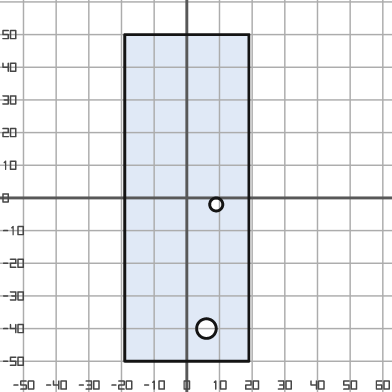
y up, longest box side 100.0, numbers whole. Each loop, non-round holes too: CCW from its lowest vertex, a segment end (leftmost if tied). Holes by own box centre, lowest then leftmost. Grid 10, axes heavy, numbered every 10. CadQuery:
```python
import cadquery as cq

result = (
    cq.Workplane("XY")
    .moveTo(-19.0, -50.0)
    .lineTo(19.0, -50.0)
    .lineTo(19.0, 50.0)
    .lineTo(-19.0, 50.0)
    .close()
    .moveTo(6.0, -40.0)
    .circle(3.0)
    .moveTo(9.0, -2.0)
    .circle(2.0)
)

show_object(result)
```